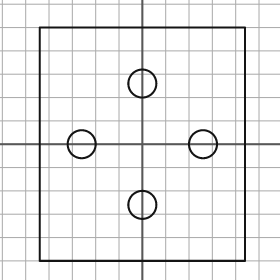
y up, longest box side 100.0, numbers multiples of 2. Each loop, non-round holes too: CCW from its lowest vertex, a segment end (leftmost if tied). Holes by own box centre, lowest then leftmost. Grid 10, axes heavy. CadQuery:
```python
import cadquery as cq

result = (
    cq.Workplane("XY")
    .moveTo(-44.0, -50.0)
    .lineTo(44.0, -50.0)
    .lineTo(44.0, 50.0)
    .lineTo(-44.0, 50.0)
    .close()
    .moveTo(0.0, -26.0)
    .circle(6.0)
    .moveTo(-26.0, 0.0)
    .circle(6.0)
    .moveTo(26.0, 0.0)
    .circle(6.0)
    .moveTo(0.0, 26.0)
    .circle(6.0)
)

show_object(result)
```